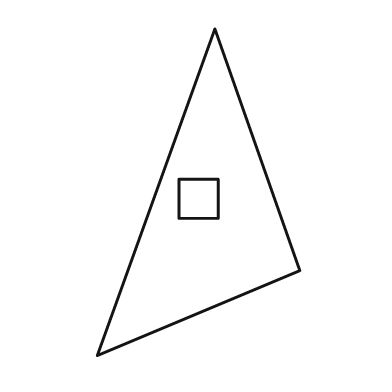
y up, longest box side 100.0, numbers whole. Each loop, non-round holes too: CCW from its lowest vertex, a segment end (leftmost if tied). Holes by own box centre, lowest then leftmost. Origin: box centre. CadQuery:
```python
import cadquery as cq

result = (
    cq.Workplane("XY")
    .moveTo(-31.0, -50.0)
    .lineTo(31.0, -24.0)
    .lineTo(5.0, 50.0)
    .close()
    .moveTo(-6.0, -8.0)
    .lineTo(6.0, -8.0)
    .lineTo(6.0, 4.0)
    .lineTo(-6.0, 4.0)
    .close()
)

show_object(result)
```